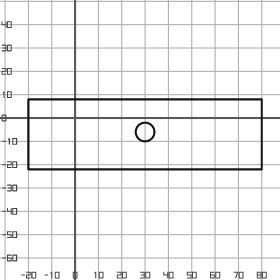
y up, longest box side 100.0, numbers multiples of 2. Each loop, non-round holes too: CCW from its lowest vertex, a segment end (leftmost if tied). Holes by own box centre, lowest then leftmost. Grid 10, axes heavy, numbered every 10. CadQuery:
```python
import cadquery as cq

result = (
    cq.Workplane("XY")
    .moveTo(-20.0, -22.0)
    .lineTo(80.0, -22.0)
    .lineTo(80.0, 8.0)
    .lineTo(-20.0, 8.0)
    .close()
    .moveTo(30.0, -6.0)
    .circle(4.0)
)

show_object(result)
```